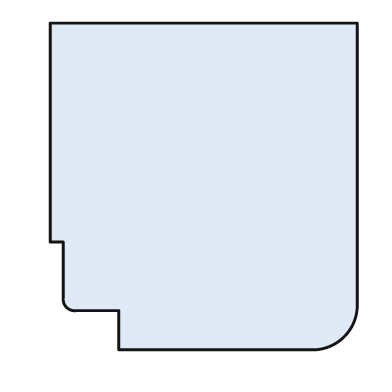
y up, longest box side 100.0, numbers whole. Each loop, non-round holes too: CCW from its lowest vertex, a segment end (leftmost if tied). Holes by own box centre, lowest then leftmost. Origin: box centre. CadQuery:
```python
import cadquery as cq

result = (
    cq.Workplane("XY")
    .moveTo(-26.0, -50.0)
    .lineTo(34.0, -50.0)
    .threePointArc((43.0, -46.0), (47.0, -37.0))
    .lineTo(47.0, 50.0)
    .lineTo(-47.0, 50.0)
    .lineTo(-47.0, -17.0)
    .lineTo(-43.0, -17.0)
    .lineTo(-43.0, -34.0)
    .threePointArc((-42.0, -37.0), (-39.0, -38.0))
    .lineTo(-26.0, -38.0)
    .close()
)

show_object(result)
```